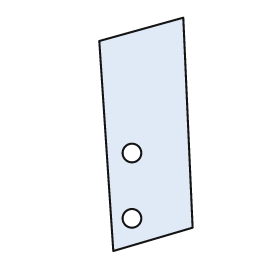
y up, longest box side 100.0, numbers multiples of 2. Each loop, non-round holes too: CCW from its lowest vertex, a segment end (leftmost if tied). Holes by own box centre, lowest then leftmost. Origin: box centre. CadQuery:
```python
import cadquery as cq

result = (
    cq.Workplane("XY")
    .moveTo(-14.0, -50.0)
    .lineTo(20.0, -40.0)
    .lineTo(16.0, 50.0)
    .lineTo(-20.0, 40.0)
    .close()
    .moveTo(-6.0, -36.0)
    .circle(4.0)
    .moveTo(-6.0, -8.0)
    .circle(4.0)
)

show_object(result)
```